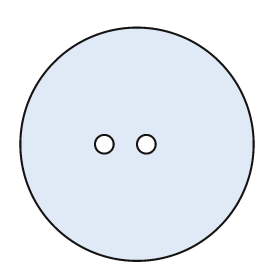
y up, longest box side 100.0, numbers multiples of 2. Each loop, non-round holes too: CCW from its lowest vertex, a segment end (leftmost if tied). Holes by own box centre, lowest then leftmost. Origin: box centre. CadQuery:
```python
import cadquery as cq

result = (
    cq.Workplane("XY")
    .moveTo(0.0, 0.0)
    .circle(50.0)
    .moveTo(-14.0, 0.0)
    .circle(4.0)
    .moveTo(4.0, 0.0)
    .circle(4.0)
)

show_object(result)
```